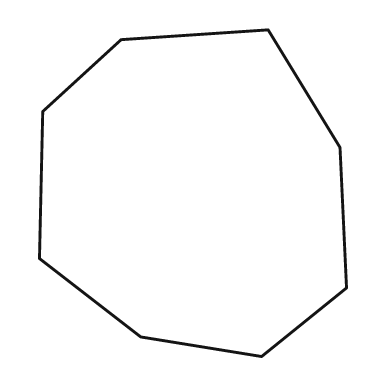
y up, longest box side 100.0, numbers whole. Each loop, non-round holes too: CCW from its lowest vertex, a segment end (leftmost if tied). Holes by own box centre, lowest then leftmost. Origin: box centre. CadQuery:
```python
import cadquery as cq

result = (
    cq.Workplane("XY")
    .moveTo(21.0, -50.0)
    .lineTo(47.0, -29.0)
    .lineTo(45.0, 14.0)
    .lineTo(23.0, 50.0)
    .lineTo(-22.0, 47.0)
    .lineTo(-46.0, 25.0)
    .lineTo(-47.0, -20.0)
    .lineTo(-16.0, -44.0)
    .close()
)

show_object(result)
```